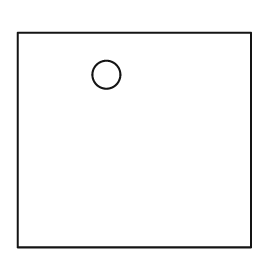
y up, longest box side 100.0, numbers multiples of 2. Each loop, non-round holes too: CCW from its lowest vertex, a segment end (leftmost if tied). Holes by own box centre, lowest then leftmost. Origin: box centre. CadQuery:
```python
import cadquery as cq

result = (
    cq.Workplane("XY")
    .moveTo(-50.0, -46.0)
    .lineTo(50.0, -46.0)
    .lineTo(50.0, 46.0)
    .lineTo(-50.0, 46.0)
    .close()
    .moveTo(-12.0, 28.0)
    .circle(6.0)
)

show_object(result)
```